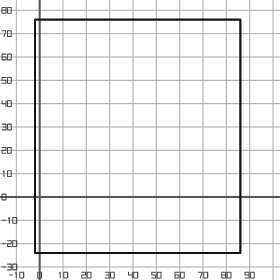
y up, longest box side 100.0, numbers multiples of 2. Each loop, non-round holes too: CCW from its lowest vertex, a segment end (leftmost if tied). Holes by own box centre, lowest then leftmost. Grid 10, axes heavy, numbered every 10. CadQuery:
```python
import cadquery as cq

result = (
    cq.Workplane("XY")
    .moveTo(-2.0, -24.0)
    .lineTo(86.0, -24.0)
    .lineTo(86.0, 76.0)
    .lineTo(-2.0, 76.0)
    .close()
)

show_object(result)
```